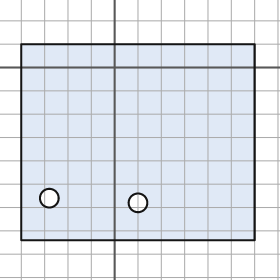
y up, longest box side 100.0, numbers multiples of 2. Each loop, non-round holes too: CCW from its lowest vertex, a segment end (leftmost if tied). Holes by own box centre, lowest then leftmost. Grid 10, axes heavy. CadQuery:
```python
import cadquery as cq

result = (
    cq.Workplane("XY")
    .moveTo(-40.0, -74.0)
    .lineTo(60.0, -74.0)
    .lineTo(60.0, 10.0)
    .lineTo(-40.0, 10.0)
    .close()
    .moveTo(10.0, -58.0)
    .circle(4.0)
    .moveTo(-28.0, -56.0)
    .circle(4.0)
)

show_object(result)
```